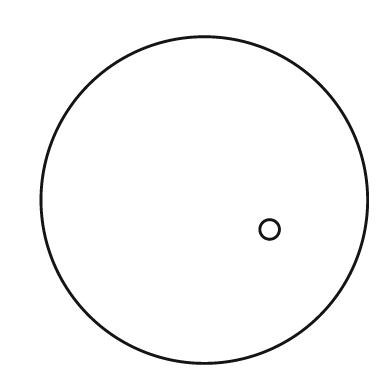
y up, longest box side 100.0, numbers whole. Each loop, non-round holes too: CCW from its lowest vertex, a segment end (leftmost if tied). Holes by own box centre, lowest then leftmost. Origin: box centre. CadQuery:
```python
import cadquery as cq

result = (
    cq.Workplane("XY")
    .moveTo(0.0, 0.0)
    .circle(50.0)
    .moveTo(20.0, -9.0)
    .circle(3.0)
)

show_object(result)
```